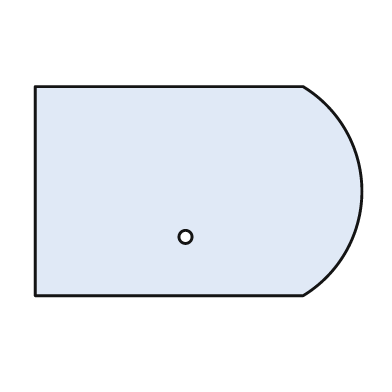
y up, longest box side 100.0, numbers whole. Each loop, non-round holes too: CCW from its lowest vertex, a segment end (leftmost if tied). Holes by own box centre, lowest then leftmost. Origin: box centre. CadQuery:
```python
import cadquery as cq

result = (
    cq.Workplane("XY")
    .moveTo(-50.0, -32.0)
    .lineTo(32.0, -32.0)
    .threePointArc((50.0, 0.0), (32.0, 32.0))
    .lineTo(-50.0, 32.0)
    .close()
    .moveTo(-4.0, -14.0)
    .circle(2.0)
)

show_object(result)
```